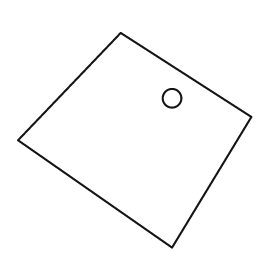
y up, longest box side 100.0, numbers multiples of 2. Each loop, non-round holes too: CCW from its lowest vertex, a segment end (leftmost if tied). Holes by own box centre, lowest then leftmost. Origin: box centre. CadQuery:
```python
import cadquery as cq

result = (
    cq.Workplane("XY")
    .moveTo(16.0, -46.0)
    .lineTo(50.0, 10.0)
    .lineTo(-6.0, 46.0)
    .lineTo(-50.0, 0.0)
    .close()
    .moveTo(16.0, 18.0)
    .circle(4.0)
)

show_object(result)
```